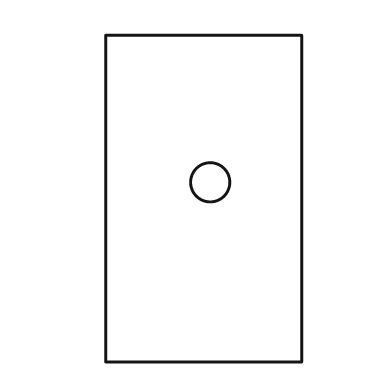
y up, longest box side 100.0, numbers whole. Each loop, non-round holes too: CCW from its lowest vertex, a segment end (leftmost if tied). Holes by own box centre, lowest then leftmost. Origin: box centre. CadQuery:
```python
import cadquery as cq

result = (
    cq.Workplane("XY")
    .moveTo(-30.0, -50.0)
    .lineTo(30.0, -50.0)
    .lineTo(30.0, 50.0)
    .lineTo(-30.0, 50.0)
    .close()
    .moveTo(2.0, 5.0)
    .circle(6.0)
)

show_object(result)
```